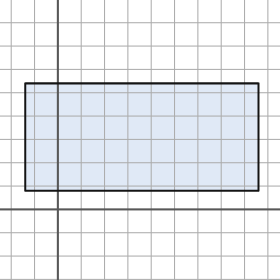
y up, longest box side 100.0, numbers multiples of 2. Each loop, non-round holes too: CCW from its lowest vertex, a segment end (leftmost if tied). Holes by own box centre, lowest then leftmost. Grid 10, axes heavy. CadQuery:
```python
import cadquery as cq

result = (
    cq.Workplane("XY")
    .moveTo(-14.0, 8.0)
    .lineTo(86.0, 8.0)
    .lineTo(86.0, 54.0)
    .lineTo(-14.0, 54.0)
    .close()
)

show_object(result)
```